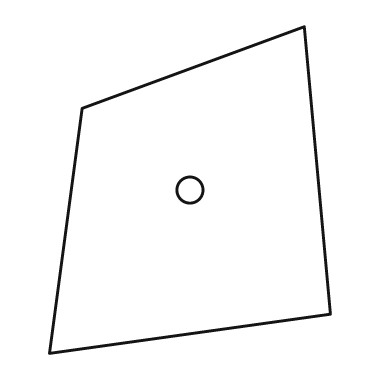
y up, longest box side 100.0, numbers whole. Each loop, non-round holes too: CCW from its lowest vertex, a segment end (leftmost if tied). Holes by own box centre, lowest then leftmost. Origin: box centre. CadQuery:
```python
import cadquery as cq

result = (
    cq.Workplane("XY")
    .moveTo(-43.0, -50.0)
    .lineTo(43.0, -38.0)
    .lineTo(35.0, 50.0)
    .lineTo(-33.0, 25.0)
    .close()
    .moveTo(0.0, 0.0)
    .circle(4.0)
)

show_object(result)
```